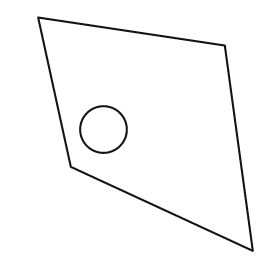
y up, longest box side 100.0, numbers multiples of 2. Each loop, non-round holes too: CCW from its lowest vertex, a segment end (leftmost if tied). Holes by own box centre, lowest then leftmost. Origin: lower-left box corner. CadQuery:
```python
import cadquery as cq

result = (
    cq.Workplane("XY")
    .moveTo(92.0, 0.0)
    .lineTo(80.0, 88.0)
    .lineTo(0.0, 100.0)
    .lineTo(14.0, 36.0)
    .close()
    .moveTo(28.0, 52.0)
    .circle(10.0)
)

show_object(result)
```